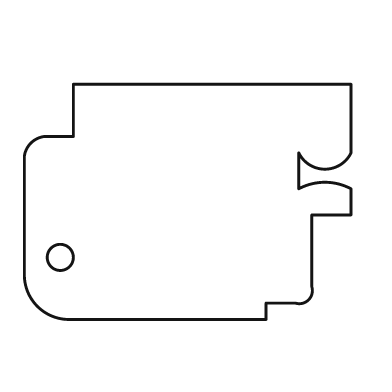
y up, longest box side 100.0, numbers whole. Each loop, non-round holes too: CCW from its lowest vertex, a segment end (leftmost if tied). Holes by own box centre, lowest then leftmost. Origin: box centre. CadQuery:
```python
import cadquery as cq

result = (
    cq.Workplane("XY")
    .moveTo(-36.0, -36.0)
    .lineTo(24.0, -36.0)
    .lineTo(24.0, -31.0)
    .lineTo(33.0, -31.0)
    .threePointArc((37.0, -30.0), (38.0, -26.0))
    .lineTo(38.0, -4.0)
    .lineTo(50.0, -4.0)
    .lineTo(50.0, 4.0)
    .threePointArc((42.0, 6.0), (34.0, 4.0))
    .lineTo(34.0, 15.0)
    .threePointArc((42.0, 10.0), (50.0, 15.0))
    .lineTo(50.0, 36.0)
    .lineTo(-35.0, 36.0)
    .lineTo(-35.0, 20.0)
    .lineTo(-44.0, 20.0)
    .threePointArc((-48.0, 18.0), (-50.0, 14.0))
    .lineTo(-50.0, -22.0)
    .threePointArc((-46.0, -32.0), (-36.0, -36.0))
    .close()
    .moveTo(-39.0, -17.0)
    .circle(4.0)
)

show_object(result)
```